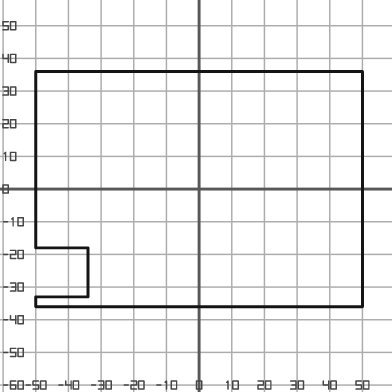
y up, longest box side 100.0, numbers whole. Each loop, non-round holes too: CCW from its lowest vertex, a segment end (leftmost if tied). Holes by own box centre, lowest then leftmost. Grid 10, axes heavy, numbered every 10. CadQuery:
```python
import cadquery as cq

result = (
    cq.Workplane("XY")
    .moveTo(-50.0, -36.0)
    .lineTo(50.0, -36.0)
    .lineTo(50.0, 36.0)
    .lineTo(-50.0, 36.0)
    .lineTo(-50.0, -18.0)
    .lineTo(-34.0, -18.0)
    .lineTo(-34.0, -33.0)
    .lineTo(-50.0, -33.0)
    .close()
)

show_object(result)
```